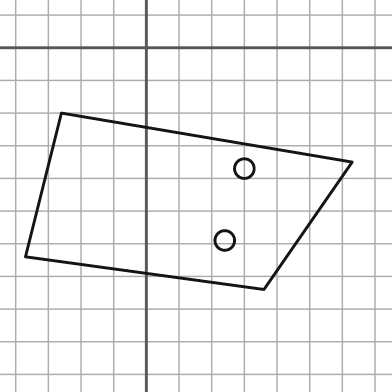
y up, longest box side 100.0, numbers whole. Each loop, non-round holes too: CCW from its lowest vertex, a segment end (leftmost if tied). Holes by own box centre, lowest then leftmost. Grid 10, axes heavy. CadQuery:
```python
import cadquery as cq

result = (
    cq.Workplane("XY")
    .moveTo(36.0, -74.0)
    .lineTo(63.0, -35.0)
    .lineTo(-26.0, -20.0)
    .lineTo(-37.0, -64.0)
    .close()
    .moveTo(24.0, -59.0)
    .circle(3.0)
    .moveTo(30.0, -37.0)
    .circle(3.0)
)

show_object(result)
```